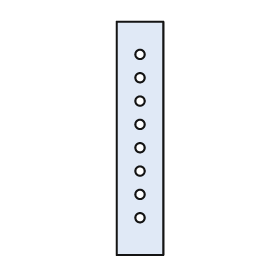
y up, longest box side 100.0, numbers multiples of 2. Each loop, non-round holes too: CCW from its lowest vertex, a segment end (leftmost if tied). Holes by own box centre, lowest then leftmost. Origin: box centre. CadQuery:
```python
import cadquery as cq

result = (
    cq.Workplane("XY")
    .moveTo(-10.0, -50.0)
    .lineTo(10.0, -50.0)
    .lineTo(10.0, 50.0)
    .lineTo(-10.0, 50.0)
    .close()
    .moveTo(0.0, -34.0)
    .circle(2.0)
    .moveTo(0.0, -24.0)
    .circle(2.0)
    .moveTo(0.0, -14.0)
    .circle(2.0)
    .moveTo(0.0, -4.0)
    .circle(2.0)
    .moveTo(0.0, 6.0)
    .circle(2.0)
    .moveTo(0.0, 16.0)
    .circle(2.0)
    .moveTo(0.0, 26.0)
    .circle(2.0)
    .moveTo(0.0, 36.0)
    .circle(2.0)
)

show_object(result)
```